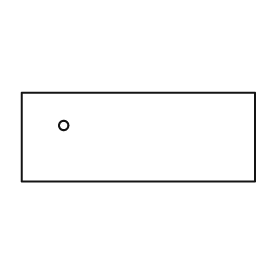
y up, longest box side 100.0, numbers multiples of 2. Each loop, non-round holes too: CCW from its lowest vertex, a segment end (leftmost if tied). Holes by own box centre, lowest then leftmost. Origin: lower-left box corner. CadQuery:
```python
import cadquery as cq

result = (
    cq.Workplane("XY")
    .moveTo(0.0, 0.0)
    .lineTo(100.0, 0.0)
    .lineTo(100.0, 38.0)
    .lineTo(0.0, 38.0)
    .close()
    .moveTo(18.0, 24.0)
    .circle(2.0)
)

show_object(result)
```